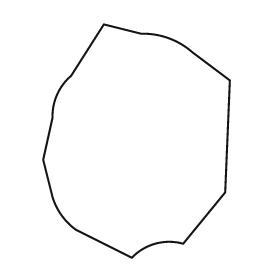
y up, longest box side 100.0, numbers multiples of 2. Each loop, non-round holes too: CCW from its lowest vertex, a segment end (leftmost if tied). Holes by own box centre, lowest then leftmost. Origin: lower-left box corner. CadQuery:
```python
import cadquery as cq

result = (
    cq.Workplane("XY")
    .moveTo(38.0, 0.0)
    .threePointArc((48.0, 6.0), (60.0, 6.0))
    .lineTo(78.0, 28.0)
    .lineTo(80.0, 76.0)
    .lineTo(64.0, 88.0)
    .threePointArc((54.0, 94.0), (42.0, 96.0))
    .lineTo(26.0, 100.0)
    .lineTo(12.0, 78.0)
    .threePointArc((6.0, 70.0), (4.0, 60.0))
    .lineTo(0.0, 42.0)
    .lineTo(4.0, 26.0)
    .threePointArc((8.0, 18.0), (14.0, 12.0))
    .close()
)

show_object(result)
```